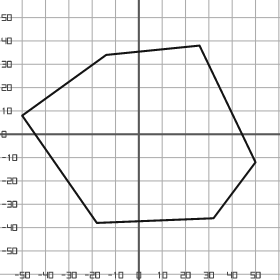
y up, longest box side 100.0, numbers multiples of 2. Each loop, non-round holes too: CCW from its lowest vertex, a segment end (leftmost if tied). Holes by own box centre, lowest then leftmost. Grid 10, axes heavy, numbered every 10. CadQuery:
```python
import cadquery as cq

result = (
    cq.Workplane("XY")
    .moveTo(-18.0, -38.0)
    .lineTo(32.0, -36.0)
    .lineTo(50.0, -12.0)
    .lineTo(26.0, 38.0)
    .lineTo(-14.0, 34.0)
    .lineTo(-50.0, 8.0)
    .close()
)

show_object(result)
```